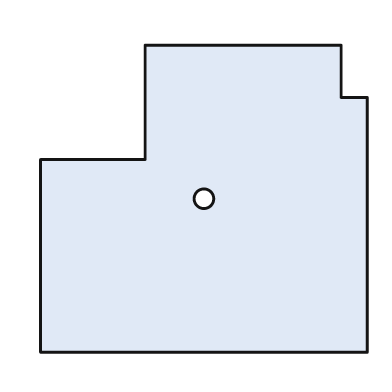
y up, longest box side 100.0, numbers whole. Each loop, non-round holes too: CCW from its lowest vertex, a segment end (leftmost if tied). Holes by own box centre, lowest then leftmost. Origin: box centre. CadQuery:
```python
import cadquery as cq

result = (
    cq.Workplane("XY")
    .moveTo(-50.0, -47.0)
    .lineTo(50.0, -47.0)
    .lineTo(50.0, 31.0)
    .lineTo(42.0, 31.0)
    .lineTo(42.0, 47.0)
    .lineTo(-18.0, 47.0)
    .lineTo(-18.0, 12.0)
    .lineTo(-50.0, 12.0)
    .close()
    .moveTo(0.0, 0.0)
    .circle(3.0)
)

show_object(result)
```